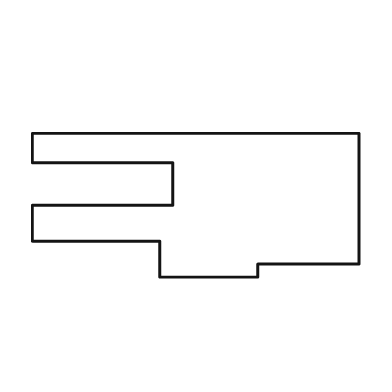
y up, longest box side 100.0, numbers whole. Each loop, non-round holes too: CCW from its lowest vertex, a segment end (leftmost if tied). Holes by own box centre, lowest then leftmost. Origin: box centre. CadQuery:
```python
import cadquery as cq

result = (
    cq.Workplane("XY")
    .moveTo(-11.0, -22.0)
    .lineTo(19.0, -22.0)
    .lineTo(19.0, -18.0)
    .lineTo(50.0, -18.0)
    .lineTo(50.0, 22.0)
    .lineTo(-50.0, 22.0)
    .lineTo(-50.0, 13.0)
    .lineTo(-7.0, 13.0)
    .lineTo(-7.0, 0.0)
    .lineTo(-50.0, 0.0)
    .lineTo(-50.0, -11.0)
    .lineTo(-11.0, -11.0)
    .close()
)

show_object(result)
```